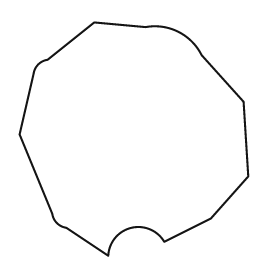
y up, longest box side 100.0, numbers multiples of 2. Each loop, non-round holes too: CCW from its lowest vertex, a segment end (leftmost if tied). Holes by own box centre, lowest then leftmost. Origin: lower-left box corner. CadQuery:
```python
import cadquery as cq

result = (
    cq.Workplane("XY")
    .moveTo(38.0, 0.0)
    .threePointArc((48.0, 12.0), (62.0, 6.0))
    .lineTo(82.0, 16.0)
    .lineTo(98.0, 34.0)
    .lineTo(96.0, 66.0)
    .lineTo(78.0, 86.0)
    .threePointArc((68.0, 96.0), (54.0, 98.0))
    .lineTo(32.0, 100.0)
    .lineTo(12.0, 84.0)
    .threePointArc((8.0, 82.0), (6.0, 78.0))
    .lineTo(0.0, 52.0)
    .lineTo(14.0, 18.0)
    .threePointArc((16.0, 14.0), (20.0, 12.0))
    .close()
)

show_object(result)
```